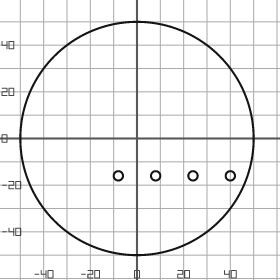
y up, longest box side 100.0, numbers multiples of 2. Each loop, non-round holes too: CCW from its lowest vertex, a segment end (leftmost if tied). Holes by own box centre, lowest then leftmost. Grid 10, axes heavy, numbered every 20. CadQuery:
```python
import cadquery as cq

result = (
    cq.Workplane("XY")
    .moveTo(0.0, 0.0)
    .circle(50.0)
    .moveTo(-8.0, -16.0)
    .circle(2.0)
    .moveTo(8.0, -16.0)
    .circle(2.0)
    .moveTo(24.0, -16.0)
    .circle(2.0)
    .moveTo(40.0, -16.0)
    .circle(2.0)
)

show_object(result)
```